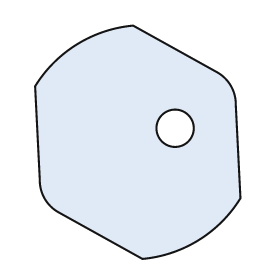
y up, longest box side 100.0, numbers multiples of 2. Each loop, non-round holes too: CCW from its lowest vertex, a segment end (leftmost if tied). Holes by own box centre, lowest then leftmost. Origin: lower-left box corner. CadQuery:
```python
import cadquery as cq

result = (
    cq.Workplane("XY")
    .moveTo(46.0, 0.0)
    .threePointArc((70.0, 8.0), (88.0, 26.0))
    .lineTo(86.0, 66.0)
    .threePointArc((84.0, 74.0), (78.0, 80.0))
    .lineTo(42.0, 100.0)
    .threePointArc((18.0, 92.0), (0.0, 74.0))
    .lineTo(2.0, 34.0)
    .threePointArc((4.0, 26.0), (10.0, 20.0))
    .close()
    .moveTo(60.0, 56.0)
    .circle(8.0)
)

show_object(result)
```